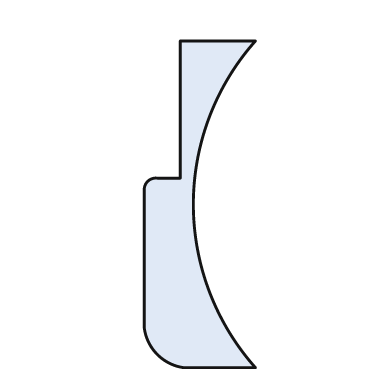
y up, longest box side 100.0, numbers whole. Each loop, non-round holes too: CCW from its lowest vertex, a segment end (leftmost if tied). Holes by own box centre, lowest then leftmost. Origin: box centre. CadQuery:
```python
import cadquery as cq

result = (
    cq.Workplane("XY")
    .moveTo(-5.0, -50.0)
    .lineTo(17.0, -50.0)
    .threePointArc((-2.0, 0.0), (17.0, 50.0))
    .lineTo(-6.0, 50.0)
    .lineTo(-6.0, 8.0)
    .lineTo(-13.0, 8.0)
    .threePointArc((-16.0, 7.0), (-17.0, 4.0))
    .lineTo(-17.0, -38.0)
    .threePointArc((-13.0, -46.0), (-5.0, -50.0))
    .close()
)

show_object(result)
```